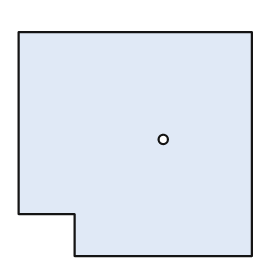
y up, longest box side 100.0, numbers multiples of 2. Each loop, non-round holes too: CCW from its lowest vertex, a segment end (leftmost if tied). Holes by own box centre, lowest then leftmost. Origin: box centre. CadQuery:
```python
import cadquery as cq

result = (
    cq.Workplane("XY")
    .moveTo(-26.0, -48.0)
    .lineTo(50.0, -48.0)
    .lineTo(50.0, 48.0)
    .lineTo(-50.0, 48.0)
    .lineTo(-50.0, -30.0)
    .lineTo(-26.0, -30.0)
    .close()
    .moveTo(12.0, 2.0)
    .circle(2.0)
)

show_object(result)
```